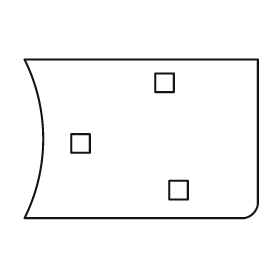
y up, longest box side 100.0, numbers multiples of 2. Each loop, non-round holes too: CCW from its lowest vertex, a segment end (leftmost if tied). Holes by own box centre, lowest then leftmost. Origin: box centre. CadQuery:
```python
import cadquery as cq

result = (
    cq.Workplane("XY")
    .moveTo(-50.0, -34.0)
    .lineTo(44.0, -34.0)
    .threePointArc((48.0, -32.0), (50.0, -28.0))
    .lineTo(50.0, 34.0)
    .lineTo(-50.0, 34.0)
    .threePointArc((-42.0, 0.0), (-50.0, -34.0))
    .close()
    .moveTo(12.0, -26.0)
    .lineTo(20.0, -26.0)
    .lineTo(20.0, -18.0)
    .lineTo(12.0, -18.0)
    .close()
    .moveTo(-30.0, -6.0)
    .lineTo(-22.0, -6.0)
    .lineTo(-22.0, 2.0)
    .lineTo(-30.0, 2.0)
    .close()
    .moveTo(6.0, 20.0)
    .lineTo(14.0, 20.0)
    .lineTo(14.0, 28.0)
    .lineTo(6.0, 28.0)
    .close()
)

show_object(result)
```